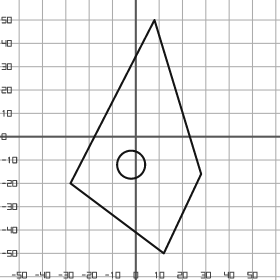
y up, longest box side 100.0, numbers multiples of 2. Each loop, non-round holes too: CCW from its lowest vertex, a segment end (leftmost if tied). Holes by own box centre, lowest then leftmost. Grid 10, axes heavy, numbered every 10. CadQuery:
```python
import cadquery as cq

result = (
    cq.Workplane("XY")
    .moveTo(12.0, -50.0)
    .lineTo(28.0, -16.0)
    .lineTo(8.0, 50.0)
    .lineTo(-28.0, -20.0)
    .close()
    .moveTo(-2.0, -12.0)
    .circle(6.0)
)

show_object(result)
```